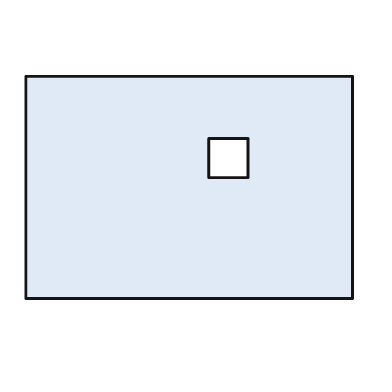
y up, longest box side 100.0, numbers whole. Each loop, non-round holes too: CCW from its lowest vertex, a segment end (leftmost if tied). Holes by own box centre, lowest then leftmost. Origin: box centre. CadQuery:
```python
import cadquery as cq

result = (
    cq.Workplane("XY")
    .moveTo(-50.0, -34.0)
    .lineTo(50.0, -34.0)
    .lineTo(50.0, 34.0)
    .lineTo(-50.0, 34.0)
    .close()
    .moveTo(6.0, 3.0)
    .lineTo(18.0, 3.0)
    .lineTo(18.0, 15.0)
    .lineTo(6.0, 15.0)
    .close()
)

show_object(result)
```